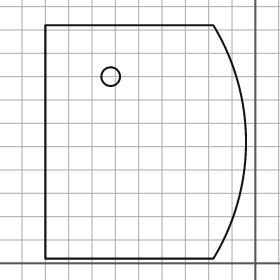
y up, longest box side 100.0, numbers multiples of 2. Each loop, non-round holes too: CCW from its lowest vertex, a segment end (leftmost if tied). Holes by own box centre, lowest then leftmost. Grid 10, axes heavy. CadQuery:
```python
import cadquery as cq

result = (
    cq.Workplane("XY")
    .moveTo(-90.0, 2.0)
    .lineTo(-18.0, 2.0)
    .threePointArc((-4.0, 52.0), (-18.0, 102.0))
    .lineTo(-90.0, 102.0)
    .close()
    .moveTo(-62.0, 80.0)
    .circle(4.0)
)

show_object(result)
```